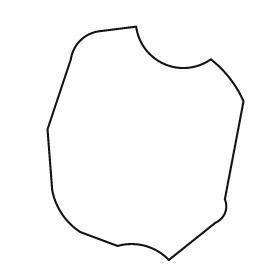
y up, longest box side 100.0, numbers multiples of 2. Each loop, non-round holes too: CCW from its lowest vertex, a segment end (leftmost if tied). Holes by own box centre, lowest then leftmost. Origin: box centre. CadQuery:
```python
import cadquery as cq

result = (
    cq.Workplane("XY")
    .moveTo(10.0, -50.0)
    .lineTo(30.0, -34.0)
    .threePointArc((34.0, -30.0), (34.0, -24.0))
    .lineTo(42.0, 18.0)
    .threePointArc((36.0, 28.0), (28.0, 36.0))
    .threePointArc((8.0, 34.0), (-4.0, 50.0))
    .lineTo(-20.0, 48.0)
    .threePointArc((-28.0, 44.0), (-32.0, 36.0))
    .lineTo(-42.0, 6.0)
    .lineTo(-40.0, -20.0)
    .threePointArc((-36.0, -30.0), (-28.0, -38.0))
    .lineTo(-12.0, -44.0)
    .threePointArc((0.0, -44.0), (10.0, -50.0))
    .close()
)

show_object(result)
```